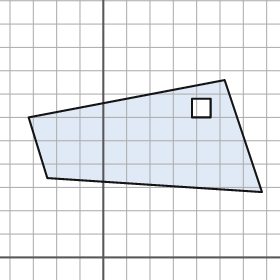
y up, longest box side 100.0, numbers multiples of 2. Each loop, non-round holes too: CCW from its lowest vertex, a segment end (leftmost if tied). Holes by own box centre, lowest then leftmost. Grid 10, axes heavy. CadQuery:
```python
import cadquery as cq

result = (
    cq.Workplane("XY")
    .moveTo(68.0, 28.0)
    .lineTo(52.0, 76.0)
    .lineTo(-32.0, 60.0)
    .lineTo(-24.0, 34.0)
    .close()
    .moveTo(38.0, 60.0)
    .lineTo(46.0, 60.0)
    .lineTo(46.0, 68.0)
    .lineTo(38.0, 68.0)
    .close()
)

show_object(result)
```